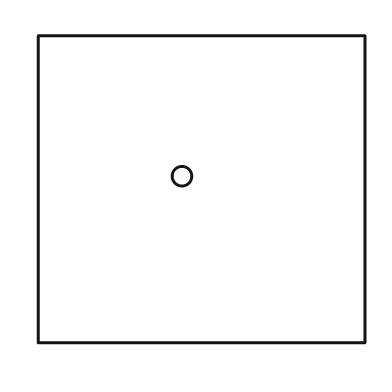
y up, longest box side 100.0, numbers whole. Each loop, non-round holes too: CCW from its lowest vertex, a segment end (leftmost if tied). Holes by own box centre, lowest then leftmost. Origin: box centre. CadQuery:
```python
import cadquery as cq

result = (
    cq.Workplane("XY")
    .moveTo(-50.0, -47.0)
    .lineTo(50.0, -47.0)
    .lineTo(50.0, 47.0)
    .lineTo(-50.0, 47.0)
    .close()
    .moveTo(-6.0, 4.0)
    .circle(3.0)
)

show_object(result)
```